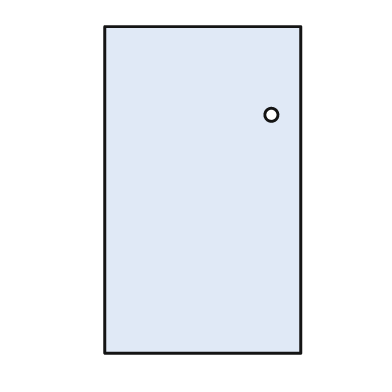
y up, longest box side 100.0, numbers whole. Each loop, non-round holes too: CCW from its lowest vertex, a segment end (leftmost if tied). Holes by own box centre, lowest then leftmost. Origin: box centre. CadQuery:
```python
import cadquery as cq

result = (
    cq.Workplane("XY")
    .moveTo(-30.0, -50.0)
    .lineTo(30.0, -50.0)
    .lineTo(30.0, 50.0)
    .lineTo(-30.0, 50.0)
    .close()
    .moveTo(21.0, 23.0)
    .circle(2.0)
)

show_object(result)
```